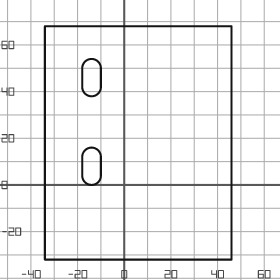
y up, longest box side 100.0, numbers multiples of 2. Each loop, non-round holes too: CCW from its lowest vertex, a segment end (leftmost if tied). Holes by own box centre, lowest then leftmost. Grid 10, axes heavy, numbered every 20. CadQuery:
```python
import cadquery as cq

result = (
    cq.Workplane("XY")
    .moveTo(-34.0, -32.0)
    .lineTo(46.0, -32.0)
    .lineTo(46.0, 68.0)
    .lineTo(-34.0, 68.0)
    .close()
    .moveTo(-18.0, 4.0)
    .threePointArc((-14.0, 0.0), (-10.0, 4.0))
    .lineTo(-10.0, 12.0)
    .threePointArc((-14.0, 16.0), (-18.0, 12.0))
    .close()
    .moveTo(-18.0, 42.0)
    .threePointArc((-14.0, 38.0), (-10.0, 42.0))
    .lineTo(-10.0, 50.0)
    .threePointArc((-14.0, 54.0), (-18.0, 50.0))
    .close()
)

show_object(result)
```